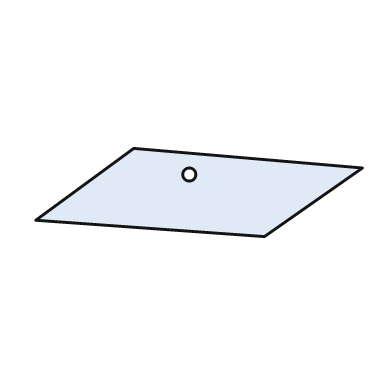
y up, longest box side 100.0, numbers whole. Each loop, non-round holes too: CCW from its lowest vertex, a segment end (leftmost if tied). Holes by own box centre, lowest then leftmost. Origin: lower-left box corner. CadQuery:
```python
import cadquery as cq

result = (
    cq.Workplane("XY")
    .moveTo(70.0, 0.0)
    .lineTo(100.0, 21.0)
    .lineTo(30.0, 27.0)
    .lineTo(0.0, 5.0)
    .close()
    .moveTo(47.0, 19.0)
    .circle(2.0)
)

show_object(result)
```